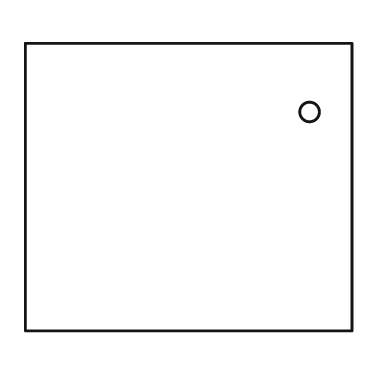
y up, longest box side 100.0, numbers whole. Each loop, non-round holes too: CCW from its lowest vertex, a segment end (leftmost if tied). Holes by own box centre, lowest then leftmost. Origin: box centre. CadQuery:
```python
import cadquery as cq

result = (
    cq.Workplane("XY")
    .moveTo(-50.0, -44.0)
    .lineTo(50.0, -44.0)
    .lineTo(50.0, 44.0)
    .lineTo(-50.0, 44.0)
    .close()
    .moveTo(37.0, 23.0)
    .circle(3.0)
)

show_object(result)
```